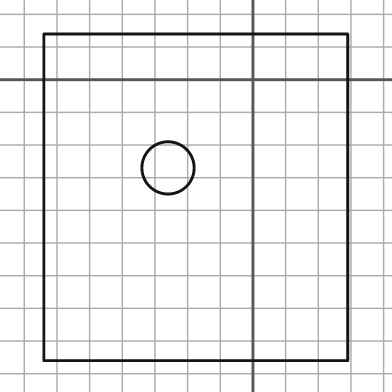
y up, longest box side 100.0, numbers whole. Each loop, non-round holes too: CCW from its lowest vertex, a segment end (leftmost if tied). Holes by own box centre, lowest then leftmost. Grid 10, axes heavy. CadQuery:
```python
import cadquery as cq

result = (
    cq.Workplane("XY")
    .moveTo(-64.0, -86.0)
    .lineTo(29.0, -86.0)
    .lineTo(29.0, 14.0)
    .lineTo(-64.0, 14.0)
    .close()
    .moveTo(-26.0, -27.0)
    .circle(8.0)
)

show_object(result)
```